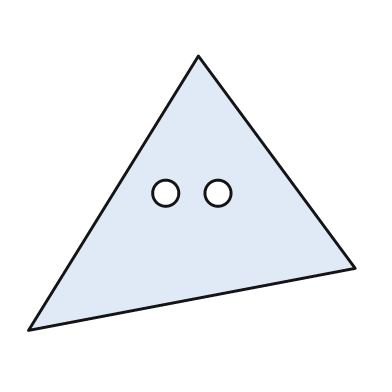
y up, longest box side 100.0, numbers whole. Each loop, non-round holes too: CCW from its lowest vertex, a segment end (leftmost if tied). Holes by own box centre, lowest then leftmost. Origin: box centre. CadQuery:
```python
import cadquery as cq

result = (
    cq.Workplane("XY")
    .moveTo(-50.0, -42.0)
    .lineTo(50.0, -23.0)
    .lineTo(2.0, 42.0)
    .close()
    .moveTo(-8.0, 0.0)
    .circle(4.0)
    .moveTo(8.0, 0.0)
    .circle(4.0)
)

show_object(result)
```